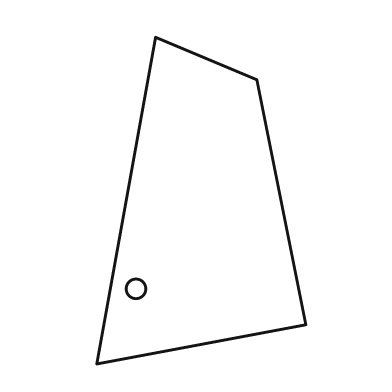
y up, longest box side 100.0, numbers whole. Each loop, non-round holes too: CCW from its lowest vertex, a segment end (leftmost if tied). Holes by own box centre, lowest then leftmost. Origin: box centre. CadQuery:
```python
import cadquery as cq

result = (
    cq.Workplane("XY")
    .moveTo(-32.0, -50.0)
    .lineTo(32.0, -38.0)
    .lineTo(17.0, 37.0)
    .lineTo(-14.0, 50.0)
    .close()
    .moveTo(-20.0, -27.0)
    .circle(3.0)
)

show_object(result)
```